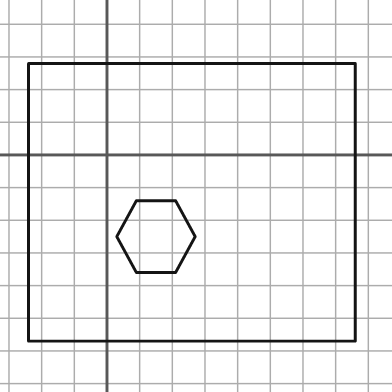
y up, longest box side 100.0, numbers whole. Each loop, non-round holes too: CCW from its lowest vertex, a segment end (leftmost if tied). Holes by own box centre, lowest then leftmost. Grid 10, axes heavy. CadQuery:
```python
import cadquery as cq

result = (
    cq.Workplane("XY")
    .moveTo(-24.0, -57.0)
    .lineTo(76.0, -57.0)
    .lineTo(76.0, 28.0)
    .lineTo(-24.0, 28.0)
    .close()
    .moveTo(9.0, -36.0)
    .lineTo(21.0, -36.0)
    .lineTo(27.0, -25.0)
    .lineTo(21.0, -14.0)
    .lineTo(9.0, -14.0)
    .lineTo(3.0, -25.0)
    .close()
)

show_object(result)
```